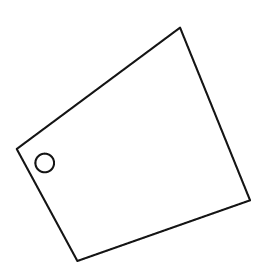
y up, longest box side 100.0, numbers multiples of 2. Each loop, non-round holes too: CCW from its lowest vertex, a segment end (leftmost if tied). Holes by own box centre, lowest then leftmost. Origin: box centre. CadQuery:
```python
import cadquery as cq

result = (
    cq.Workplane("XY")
    .moveTo(-24.0, -50.0)
    .lineTo(50.0, -24.0)
    .lineTo(20.0, 50.0)
    .lineTo(-50.0, -2.0)
    .close()
    .moveTo(-38.0, -8.0)
    .circle(4.0)
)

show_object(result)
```